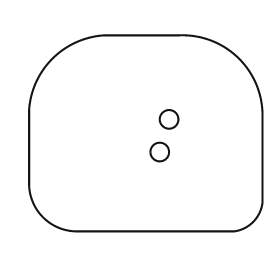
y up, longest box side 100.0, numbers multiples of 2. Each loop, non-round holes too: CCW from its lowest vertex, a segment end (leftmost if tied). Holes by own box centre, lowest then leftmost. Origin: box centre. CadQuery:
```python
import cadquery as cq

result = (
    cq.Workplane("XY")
    .moveTo(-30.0, -42.0)
    .lineTo(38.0, -42.0)
    .threePointArc((46.0, -38.0), (50.0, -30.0))
    .lineTo(50.0, 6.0)
    .threePointArc((40.0, 32.0), (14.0, 42.0))
    .lineTo(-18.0, 42.0)
    .threePointArc((-40.0, 32.0), (-50.0, 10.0))
    .lineTo(-50.0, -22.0)
    .threePointArc((-44.0, -36.0), (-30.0, -42.0))
    .close()
    .moveTo(6.0, -8.0)
    .circle(4.0)
    .moveTo(10.0, 6.0)
    .circle(4.0)
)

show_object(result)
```